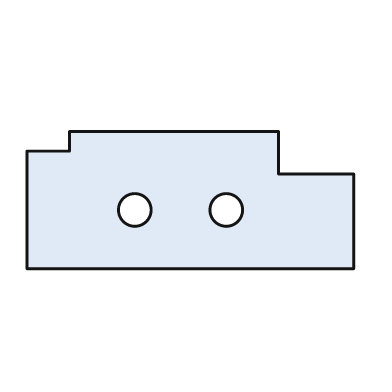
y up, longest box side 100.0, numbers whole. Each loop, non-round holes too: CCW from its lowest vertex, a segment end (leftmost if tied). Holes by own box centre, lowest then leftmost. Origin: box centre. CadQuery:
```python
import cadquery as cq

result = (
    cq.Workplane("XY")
    .moveTo(-50.0, -21.0)
    .lineTo(50.0, -21.0)
    .lineTo(50.0, 8.0)
    .lineTo(27.0, 8.0)
    .lineTo(27.0, 21.0)
    .lineTo(-37.0, 21.0)
    .lineTo(-37.0, 15.0)
    .lineTo(-50.0, 15.0)
    .close()
    .moveTo(-17.0, -3.0)
    .circle(5.0)
    .moveTo(11.0, -3.0)
    .circle(5.0)
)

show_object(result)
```